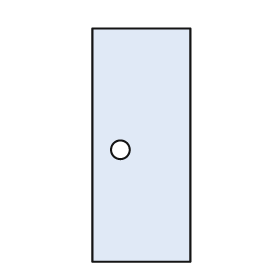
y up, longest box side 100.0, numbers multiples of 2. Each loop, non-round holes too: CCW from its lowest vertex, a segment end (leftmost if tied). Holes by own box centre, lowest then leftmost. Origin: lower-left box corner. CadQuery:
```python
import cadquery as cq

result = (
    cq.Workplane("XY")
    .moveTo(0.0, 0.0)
    .lineTo(42.0, 0.0)
    .lineTo(42.0, 100.0)
    .lineTo(0.0, 100.0)
    .close()
    .moveTo(12.0, 48.0)
    .circle(4.0)
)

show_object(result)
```